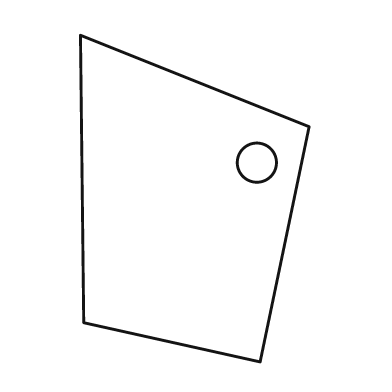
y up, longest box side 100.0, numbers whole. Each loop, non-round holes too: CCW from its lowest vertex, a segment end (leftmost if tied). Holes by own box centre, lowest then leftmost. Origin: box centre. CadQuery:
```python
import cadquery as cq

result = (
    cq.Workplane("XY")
    .moveTo(20.0, -50.0)
    .lineTo(35.0, 22.0)
    .lineTo(-35.0, 50.0)
    .lineTo(-34.0, -38.0)
    .close()
    .moveTo(19.0, 11.0)
    .circle(6.0)
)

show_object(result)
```